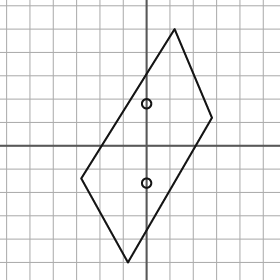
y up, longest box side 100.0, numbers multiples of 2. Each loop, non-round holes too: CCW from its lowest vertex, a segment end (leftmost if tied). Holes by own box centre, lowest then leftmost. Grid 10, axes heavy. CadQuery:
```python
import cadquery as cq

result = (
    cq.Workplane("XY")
    .moveTo(-8.0, -50.0)
    .lineTo(28.0, 12.0)
    .lineTo(12.0, 50.0)
    .lineTo(-28.0, -14.0)
    .close()
    .moveTo(0.0, -16.0)
    .circle(2.0)
    .moveTo(0.0, 18.0)
    .circle(2.0)
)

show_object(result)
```